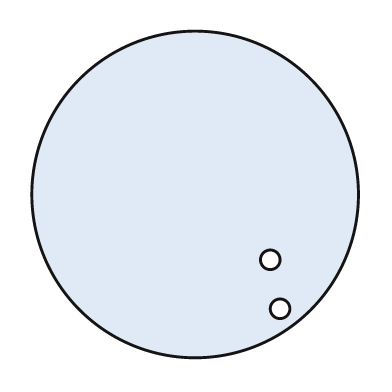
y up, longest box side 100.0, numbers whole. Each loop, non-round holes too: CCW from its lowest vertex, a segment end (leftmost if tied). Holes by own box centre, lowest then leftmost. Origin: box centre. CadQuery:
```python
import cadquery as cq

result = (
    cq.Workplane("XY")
    .moveTo(0.0, 0.0)
    .circle(50.0)
    .moveTo(26.0, -35.0)
    .circle(3.0)
    .moveTo(23.0, -20.0)
    .circle(3.0)
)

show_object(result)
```